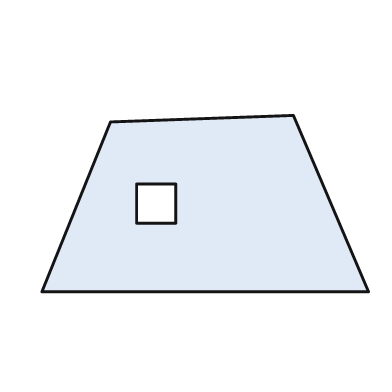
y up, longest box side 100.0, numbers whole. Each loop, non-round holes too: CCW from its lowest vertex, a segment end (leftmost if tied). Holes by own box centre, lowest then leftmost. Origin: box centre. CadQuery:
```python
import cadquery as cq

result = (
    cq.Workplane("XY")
    .moveTo(-50.0, -27.0)
    .lineTo(50.0, -27.0)
    .lineTo(27.0, 27.0)
    .lineTo(-29.0, 25.0)
    .close()
    .moveTo(-21.0, -6.0)
    .lineTo(-9.0, -6.0)
    .lineTo(-9.0, 6.0)
    .lineTo(-21.0, 6.0)
    .close()
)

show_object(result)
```